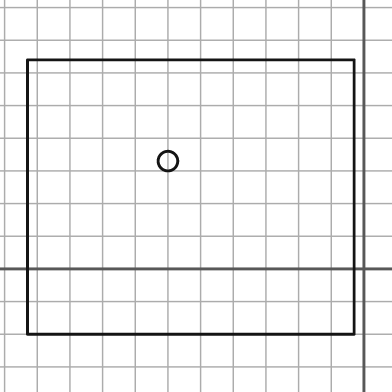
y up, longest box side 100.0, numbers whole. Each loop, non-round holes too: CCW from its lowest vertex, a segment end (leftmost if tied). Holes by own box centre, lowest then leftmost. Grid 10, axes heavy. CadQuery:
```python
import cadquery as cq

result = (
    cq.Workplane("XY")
    .moveTo(-103.0, -20.0)
    .lineTo(-3.0, -20.0)
    .lineTo(-3.0, 64.0)
    .lineTo(-103.0, 64.0)
    .close()
    .moveTo(-60.0, 33.0)
    .circle(3.0)
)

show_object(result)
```